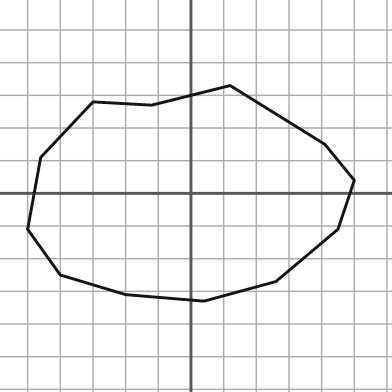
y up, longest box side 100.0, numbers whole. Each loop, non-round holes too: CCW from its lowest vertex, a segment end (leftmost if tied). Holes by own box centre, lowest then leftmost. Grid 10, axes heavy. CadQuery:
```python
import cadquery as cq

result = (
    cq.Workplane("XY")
    .moveTo(4.0, -33.0)
    .lineTo(26.0, -27.0)
    .lineTo(45.0, -11.0)
    .lineTo(50.0, 4.0)
    .lineTo(41.0, 15.0)
    .lineTo(12.0, 33.0)
    .lineTo(-12.0, 27.0)
    .lineTo(-30.0, 28.0)
    .lineTo(-46.0, 11.0)
    .lineTo(-50.0, -11.0)
    .lineTo(-40.0, -25.0)
    .lineTo(-20.0, -31.0)
    .close()
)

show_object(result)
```